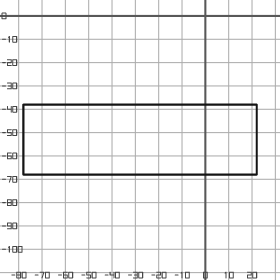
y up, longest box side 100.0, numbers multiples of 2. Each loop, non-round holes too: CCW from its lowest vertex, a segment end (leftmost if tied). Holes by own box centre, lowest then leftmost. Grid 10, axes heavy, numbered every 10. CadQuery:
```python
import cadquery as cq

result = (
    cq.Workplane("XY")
    .moveTo(-78.0, -68.0)
    .lineTo(22.0, -68.0)
    .lineTo(22.0, -38.0)
    .lineTo(-78.0, -38.0)
    .close()
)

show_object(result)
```